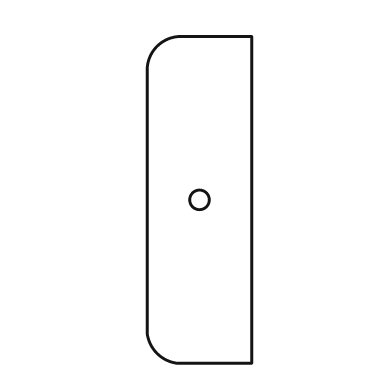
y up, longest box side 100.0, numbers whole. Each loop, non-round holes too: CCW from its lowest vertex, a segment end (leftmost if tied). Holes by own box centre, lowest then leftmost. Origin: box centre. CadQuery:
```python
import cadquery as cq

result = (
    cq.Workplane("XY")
    .moveTo(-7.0, -50.0)
    .lineTo(16.0, -50.0)
    .lineTo(16.0, 50.0)
    .lineTo(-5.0, 50.0)
    .threePointArc((-13.0, 47.0), (-16.0, 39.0))
    .lineTo(-16.0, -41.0)
    .threePointArc((-13.0, -47.0), (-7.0, -50.0))
    .close()
    .moveTo(0.0, 0.0)
    .circle(3.0)
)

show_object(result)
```